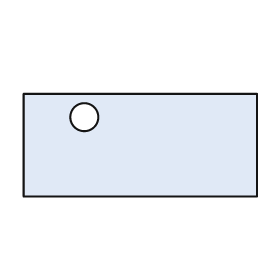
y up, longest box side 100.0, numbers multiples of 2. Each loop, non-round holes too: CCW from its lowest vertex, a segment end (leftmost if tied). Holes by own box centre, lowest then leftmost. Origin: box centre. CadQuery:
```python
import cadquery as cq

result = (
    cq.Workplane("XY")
    .moveTo(-50.0, -22.0)
    .lineTo(50.0, -22.0)
    .lineTo(50.0, 22.0)
    .lineTo(-50.0, 22.0)
    .close()
    .moveTo(-24.0, 12.0)
    .circle(6.0)
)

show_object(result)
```